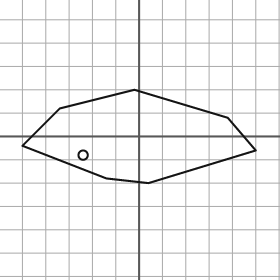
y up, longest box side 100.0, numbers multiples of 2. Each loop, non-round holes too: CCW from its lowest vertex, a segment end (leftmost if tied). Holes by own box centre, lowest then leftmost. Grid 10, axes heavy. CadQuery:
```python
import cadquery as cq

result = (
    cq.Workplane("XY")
    .moveTo(4.0, -20.0)
    .lineTo(50.0, -6.0)
    .lineTo(38.0, 8.0)
    .lineTo(-2.0, 20.0)
    .lineTo(-34.0, 12.0)
    .lineTo(-50.0, -4.0)
    .lineTo(-14.0, -18.0)
    .close()
    .moveTo(-24.0, -8.0)
    .circle(2.0)
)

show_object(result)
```